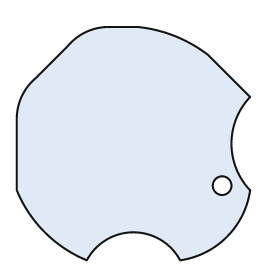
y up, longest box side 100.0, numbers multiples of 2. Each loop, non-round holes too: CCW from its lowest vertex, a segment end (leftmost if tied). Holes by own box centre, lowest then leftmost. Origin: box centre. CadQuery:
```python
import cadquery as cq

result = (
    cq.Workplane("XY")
    .moveTo(-20.0, -50.0)
    .threePointArc((0.0, -38.0), (20.0, -50.0))
    .threePointArc((40.0, -40.0), (50.0, -20.0))
    .threePointArc((42.0, 0.0), (50.0, 20.0))
    .lineTo(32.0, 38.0)
    .threePointArc((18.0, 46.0), (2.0, 50.0))
    .lineTo(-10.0, 50.0)
    .threePointArc((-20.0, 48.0), (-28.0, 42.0))
    .lineTo(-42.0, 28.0)
    .threePointArc((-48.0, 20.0), (-50.0, 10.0))
    .lineTo(-50.0, -20.0)
    .threePointArc((-38.0, -38.0), (-20.0, -50.0))
    .close()
    .moveTo(38.0, -18.0)
    .circle(4.0)
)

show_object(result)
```